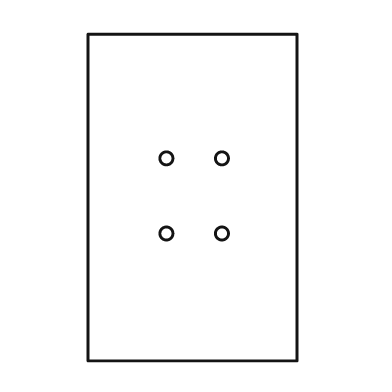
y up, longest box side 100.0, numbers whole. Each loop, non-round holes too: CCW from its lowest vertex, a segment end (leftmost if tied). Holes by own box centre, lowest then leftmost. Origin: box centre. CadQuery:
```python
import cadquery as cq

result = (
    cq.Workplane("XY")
    .moveTo(-32.0, -50.0)
    .lineTo(32.0, -50.0)
    .lineTo(32.0, 50.0)
    .lineTo(-32.0, 50.0)
    .close()
    .moveTo(-8.0, -11.0)
    .circle(2.0)
    .moveTo(9.0, -11.0)
    .circle(2.0)
    .moveTo(-8.0, 12.0)
    .circle(2.0)
    .moveTo(9.0, 12.0)
    .circle(2.0)
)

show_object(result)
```